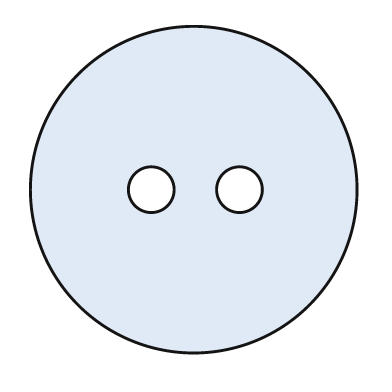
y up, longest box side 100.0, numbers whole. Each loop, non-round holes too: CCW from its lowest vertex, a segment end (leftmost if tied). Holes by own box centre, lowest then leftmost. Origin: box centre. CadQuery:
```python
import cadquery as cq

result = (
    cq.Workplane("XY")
    .moveTo(0.0, 0.0)
    .circle(50.0)
    .moveTo(-13.0, 0.0)
    .circle(7.0)
    .moveTo(14.0, 0.0)
    .circle(7.0)
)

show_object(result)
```